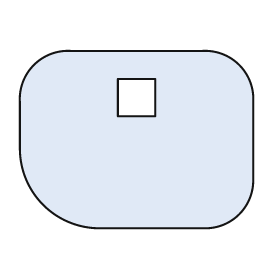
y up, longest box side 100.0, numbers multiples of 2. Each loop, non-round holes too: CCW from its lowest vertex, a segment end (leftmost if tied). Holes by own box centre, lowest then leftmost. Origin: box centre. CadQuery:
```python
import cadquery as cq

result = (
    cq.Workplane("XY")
    .moveTo(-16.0, -38.0)
    .lineTo(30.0, -38.0)
    .threePointArc((44.0, -32.0), (50.0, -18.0))
    .lineTo(50.0, 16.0)
    .threePointArc((44.0, 32.0), (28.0, 38.0))
    .lineTo(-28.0, 38.0)
    .threePointArc((-44.0, 32.0), (-50.0, 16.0))
    .lineTo(-50.0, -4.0)
    .threePointArc((-40.0, -28.0), (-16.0, -38.0))
    .close()
    .moveTo(-8.0, 10.0)
    .lineTo(8.0, 10.0)
    .lineTo(8.0, 26.0)
    .lineTo(-8.0, 26.0)
    .close()
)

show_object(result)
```